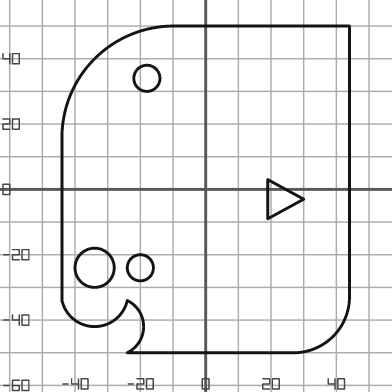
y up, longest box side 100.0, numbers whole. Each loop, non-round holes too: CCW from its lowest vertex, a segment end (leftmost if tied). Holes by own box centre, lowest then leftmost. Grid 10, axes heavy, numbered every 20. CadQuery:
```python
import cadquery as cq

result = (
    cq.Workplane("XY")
    .moveTo(-24.0, -50.0)
    .lineTo(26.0, -50.0)
    .threePointArc((39.0, -45.0), (44.0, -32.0))
    .lineTo(44.0, 50.0)
    .lineTo(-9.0, 50.0)
    .threePointArc((-34.0, 40.0), (-44.0, 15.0))
    .lineTo(-44.0, -34.0)
    .threePointArc((-34.0, -42.0), (-24.0, -34.0))
    .threePointArc((-19.0, -42.0), (-24.0, -50.0))
    .close()
    .moveTo(-34.0, -24.0)
    .circle(6.0)
    .moveTo(-20.0, -24.0)
    .circle(4.0)
    .moveTo(19.0, -9.0)
    .lineTo(30.0, -3.0)
    .lineTo(19.0, 3.0)
    .close()
    .moveTo(-18.0, 34.0)
    .circle(4.0)
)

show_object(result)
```